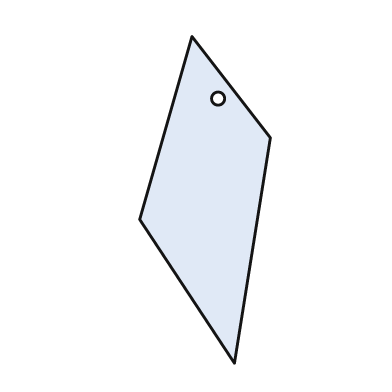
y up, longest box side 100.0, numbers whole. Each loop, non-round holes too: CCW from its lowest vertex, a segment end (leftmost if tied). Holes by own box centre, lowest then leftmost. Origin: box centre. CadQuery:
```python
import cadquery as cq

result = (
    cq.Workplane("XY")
    .moveTo(9.0, -50.0)
    .lineTo(20.0, 19.0)
    .lineTo(-4.0, 50.0)
    .lineTo(-20.0, -6.0)
    .close()
    .moveTo(4.0, 31.0)
    .circle(2.0)
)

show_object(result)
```